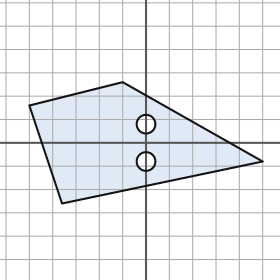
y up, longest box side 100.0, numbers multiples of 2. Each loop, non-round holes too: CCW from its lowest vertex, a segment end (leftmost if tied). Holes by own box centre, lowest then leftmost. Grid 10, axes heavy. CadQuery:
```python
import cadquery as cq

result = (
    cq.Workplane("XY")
    .moveTo(-36.0, -26.0)
    .lineTo(50.0, -8.0)
    .lineTo(-10.0, 26.0)
    .lineTo(-50.0, 16.0)
    .close()
    .moveTo(0.0, -8.0)
    .circle(4.0)
    .moveTo(0.0, 8.0)
    .circle(4.0)
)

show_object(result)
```